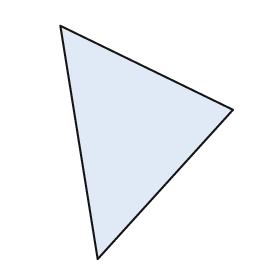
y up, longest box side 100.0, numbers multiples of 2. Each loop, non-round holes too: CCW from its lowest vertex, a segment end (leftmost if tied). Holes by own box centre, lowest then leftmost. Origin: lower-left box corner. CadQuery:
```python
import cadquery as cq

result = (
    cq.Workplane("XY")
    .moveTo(16.0, 0.0)
    .lineTo(74.0, 64.0)
    .lineTo(0.0, 100.0)
    .close()
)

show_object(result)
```